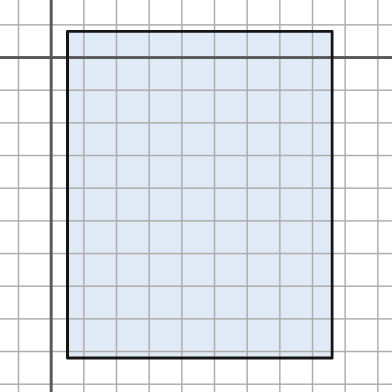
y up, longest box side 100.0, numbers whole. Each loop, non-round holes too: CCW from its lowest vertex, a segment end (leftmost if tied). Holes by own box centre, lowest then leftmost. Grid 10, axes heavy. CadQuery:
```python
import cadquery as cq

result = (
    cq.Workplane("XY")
    .moveTo(5.0, -92.0)
    .lineTo(86.0, -92.0)
    .lineTo(86.0, 8.0)
    .lineTo(5.0, 8.0)
    .close()
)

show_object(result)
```